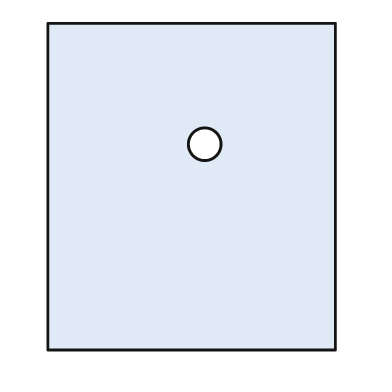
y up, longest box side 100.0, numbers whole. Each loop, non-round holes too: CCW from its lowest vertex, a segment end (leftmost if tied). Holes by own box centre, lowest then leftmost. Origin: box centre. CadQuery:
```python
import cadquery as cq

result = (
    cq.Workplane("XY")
    .moveTo(-44.0, -50.0)
    .lineTo(44.0, -50.0)
    .lineTo(44.0, 50.0)
    .lineTo(-44.0, 50.0)
    .close()
    .moveTo(4.0, 13.0)
    .circle(5.0)
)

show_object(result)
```